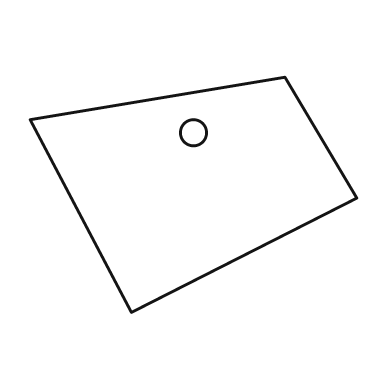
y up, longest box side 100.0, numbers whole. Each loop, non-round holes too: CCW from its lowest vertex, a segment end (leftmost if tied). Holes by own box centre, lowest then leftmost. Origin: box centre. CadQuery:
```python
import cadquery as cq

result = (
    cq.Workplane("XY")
    .moveTo(-19.0, -36.0)
    .lineTo(50.0, -1.0)
    .lineTo(28.0, 36.0)
    .lineTo(-50.0, 23.0)
    .close()
    .moveTo(0.0, 19.0)
    .circle(4.0)
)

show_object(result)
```